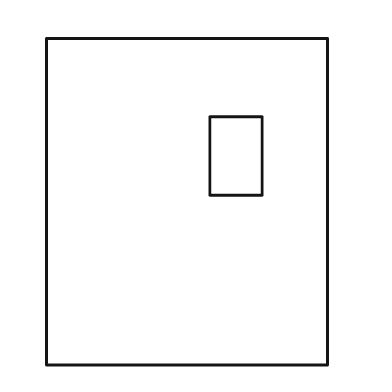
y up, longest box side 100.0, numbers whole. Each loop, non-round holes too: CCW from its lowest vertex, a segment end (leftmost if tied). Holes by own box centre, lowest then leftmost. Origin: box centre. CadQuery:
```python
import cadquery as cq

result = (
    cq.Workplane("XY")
    .moveTo(-43.0, -50.0)
    .lineTo(43.0, -50.0)
    .lineTo(43.0, 50.0)
    .lineTo(-43.0, 50.0)
    .close()
    .moveTo(7.0, 2.0)
    .lineTo(23.0, 2.0)
    .lineTo(23.0, 26.0)
    .lineTo(7.0, 26.0)
    .close()
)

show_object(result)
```